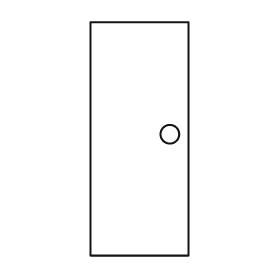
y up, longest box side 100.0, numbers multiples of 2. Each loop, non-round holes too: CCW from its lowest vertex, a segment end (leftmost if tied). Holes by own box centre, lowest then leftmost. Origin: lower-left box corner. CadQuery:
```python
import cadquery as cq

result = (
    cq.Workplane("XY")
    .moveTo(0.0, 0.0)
    .lineTo(42.0, 0.0)
    .lineTo(42.0, 100.0)
    .lineTo(0.0, 100.0)
    .close()
    .moveTo(34.0, 52.0)
    .circle(4.0)
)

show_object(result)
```